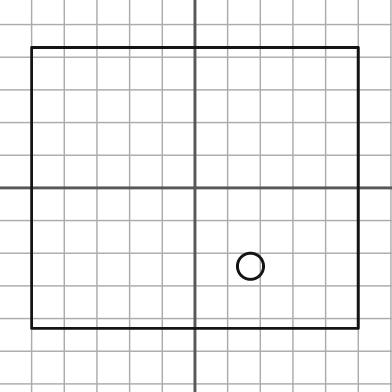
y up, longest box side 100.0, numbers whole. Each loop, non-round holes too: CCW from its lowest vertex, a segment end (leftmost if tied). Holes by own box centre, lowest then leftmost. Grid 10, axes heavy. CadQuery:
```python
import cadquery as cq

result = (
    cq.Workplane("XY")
    .moveTo(-50.0, -43.0)
    .lineTo(50.0, -43.0)
    .lineTo(50.0, 43.0)
    .lineTo(-50.0, 43.0)
    .close()
    .moveTo(17.0, -24.0)
    .circle(4.0)
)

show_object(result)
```